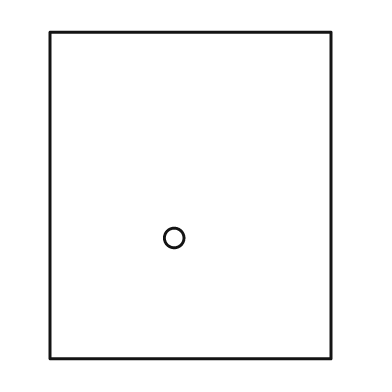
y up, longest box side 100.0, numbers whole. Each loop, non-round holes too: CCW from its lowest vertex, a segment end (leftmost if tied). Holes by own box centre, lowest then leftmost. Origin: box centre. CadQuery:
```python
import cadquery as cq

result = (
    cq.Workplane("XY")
    .moveTo(-43.0, -50.0)
    .lineTo(43.0, -50.0)
    .lineTo(43.0, 50.0)
    .lineTo(-43.0, 50.0)
    .close()
    .moveTo(-5.0, -13.0)
    .circle(3.0)
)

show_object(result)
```